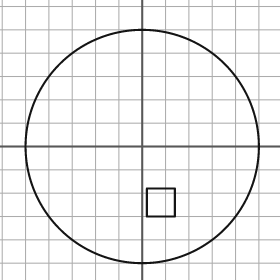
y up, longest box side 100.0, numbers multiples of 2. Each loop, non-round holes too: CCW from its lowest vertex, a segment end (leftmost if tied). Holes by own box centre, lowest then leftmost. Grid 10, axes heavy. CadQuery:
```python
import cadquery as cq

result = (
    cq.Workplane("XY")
    .moveTo(0.0, 0.0)
    .circle(50.0)
    .moveTo(2.0, -30.0)
    .lineTo(14.0, -30.0)
    .lineTo(14.0, -18.0)
    .lineTo(2.0, -18.0)
    .close()
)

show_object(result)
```